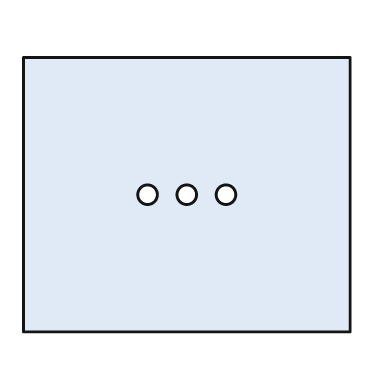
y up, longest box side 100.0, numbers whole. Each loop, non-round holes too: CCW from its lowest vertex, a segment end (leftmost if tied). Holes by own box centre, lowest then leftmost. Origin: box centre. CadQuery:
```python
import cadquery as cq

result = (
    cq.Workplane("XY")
    .moveTo(-50.0, -42.0)
    .lineTo(50.0, -42.0)
    .lineTo(50.0, 42.0)
    .lineTo(-50.0, 42.0)
    .close()
    .moveTo(-12.0, 0.0)
    .circle(3.0)
    .moveTo(0.0, 0.0)
    .circle(3.0)
    .moveTo(12.0, 0.0)
    .circle(3.0)
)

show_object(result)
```